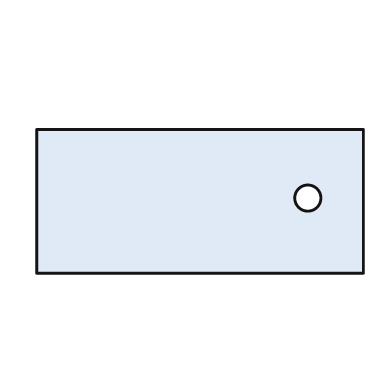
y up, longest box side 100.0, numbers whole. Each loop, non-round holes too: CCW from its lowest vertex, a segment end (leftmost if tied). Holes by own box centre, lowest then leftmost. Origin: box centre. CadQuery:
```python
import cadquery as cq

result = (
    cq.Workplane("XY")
    .moveTo(-50.0, -22.0)
    .lineTo(50.0, -22.0)
    .lineTo(50.0, 22.0)
    .lineTo(-50.0, 22.0)
    .close()
    .moveTo(33.0, 1.0)
    .circle(4.0)
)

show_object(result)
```